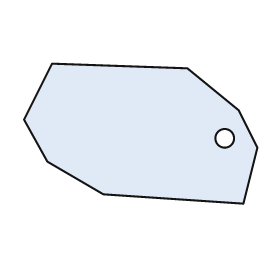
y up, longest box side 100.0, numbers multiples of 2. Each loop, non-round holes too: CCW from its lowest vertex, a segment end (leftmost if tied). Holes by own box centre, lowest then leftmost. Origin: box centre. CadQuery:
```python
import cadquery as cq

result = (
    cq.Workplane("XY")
    .moveTo(44.0, -30.0)
    .lineTo(50.0, -6.0)
    .lineTo(42.0, 10.0)
    .lineTo(20.0, 28.0)
    .lineTo(-38.0, 30.0)
    .lineTo(-50.0, 6.0)
    .lineTo(-40.0, -12.0)
    .lineTo(-16.0, -26.0)
    .close()
    .moveTo(36.0, -2.0)
    .circle(4.0)
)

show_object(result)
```